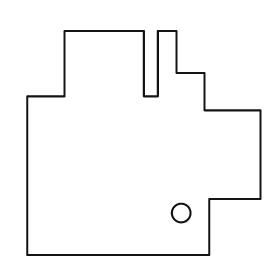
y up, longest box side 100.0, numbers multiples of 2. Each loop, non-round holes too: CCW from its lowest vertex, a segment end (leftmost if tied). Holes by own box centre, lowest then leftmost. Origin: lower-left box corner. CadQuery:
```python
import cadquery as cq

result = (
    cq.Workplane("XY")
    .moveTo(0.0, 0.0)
    .lineTo(78.0, 0.0)
    .lineTo(78.0, 24.0)
    .lineTo(100.0, 24.0)
    .lineTo(100.0, 62.0)
    .lineTo(76.0, 62.0)
    .lineTo(76.0, 78.0)
    .lineTo(64.0, 78.0)
    .lineTo(64.0, 96.0)
    .lineTo(56.0, 96.0)
    .lineTo(56.0, 68.0)
    .lineTo(50.0, 68.0)
    .lineTo(50.0, 96.0)
    .lineTo(16.0, 96.0)
    .lineTo(16.0, 68.0)
    .lineTo(0.0, 68.0)
    .close()
    .moveTo(66.0, 18.0)
    .circle(4.0)
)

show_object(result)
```